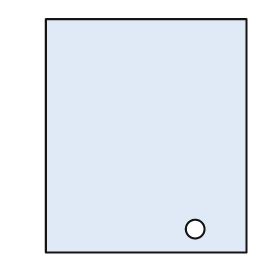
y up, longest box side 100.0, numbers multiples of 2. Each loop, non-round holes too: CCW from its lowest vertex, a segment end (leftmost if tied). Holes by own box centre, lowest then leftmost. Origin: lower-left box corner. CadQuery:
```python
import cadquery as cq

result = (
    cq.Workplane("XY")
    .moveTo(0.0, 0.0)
    .lineTo(86.0, 0.0)
    .lineTo(86.0, 100.0)
    .lineTo(0.0, 100.0)
    .close()
    .moveTo(64.0, 10.0)
    .circle(4.0)
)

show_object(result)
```